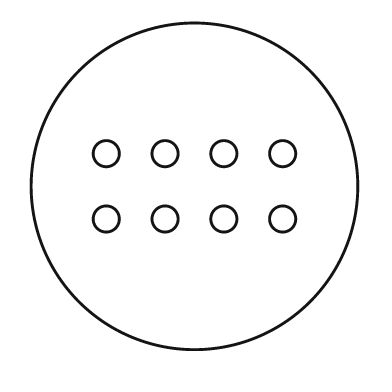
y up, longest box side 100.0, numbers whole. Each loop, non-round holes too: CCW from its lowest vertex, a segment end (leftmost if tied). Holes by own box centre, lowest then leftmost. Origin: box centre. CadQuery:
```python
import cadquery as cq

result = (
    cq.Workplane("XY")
    .moveTo(0.0, 0.0)
    .circle(50.0)
    .moveTo(-27.0, -10.0)
    .circle(4.0)
    .moveTo(-9.0, -10.0)
    .circle(4.0)
    .moveTo(9.0, -10.0)
    .circle(4.0)
    .moveTo(27.0, -10.0)
    .circle(4.0)
    .moveTo(-27.0, 10.0)
    .circle(4.0)
    .moveTo(-9.0, 10.0)
    .circle(4.0)
    .moveTo(9.0, 10.0)
    .circle(4.0)
    .moveTo(27.0, 10.0)
    .circle(4.0)
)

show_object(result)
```